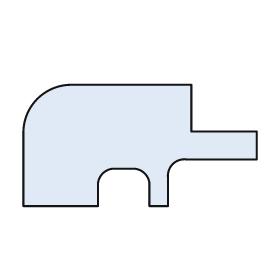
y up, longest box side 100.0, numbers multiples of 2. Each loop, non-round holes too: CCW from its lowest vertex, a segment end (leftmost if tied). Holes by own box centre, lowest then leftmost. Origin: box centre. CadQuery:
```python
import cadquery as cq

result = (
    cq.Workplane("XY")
    .moveTo(-50.0, -26.0)
    .lineTo(-18.0, -26.0)
    .lineTo(-18.0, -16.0)
    .threePointArc((-16.0, -12.0), (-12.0, -10.0))
    .lineTo(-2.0, -10.0)
    .threePointArc((2.0, -12.0), (4.0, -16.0))
    .lineTo(4.0, -26.0)
    .lineTo(12.0, -26.0)
    .lineTo(12.0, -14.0)
    .threePointArc((14.0, -8.0), (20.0, -6.0))
    .lineTo(50.0, -6.0)
    .lineTo(50.0, 6.0)
    .lineTo(22.0, 6.0)
    .lineTo(22.0, 26.0)
    .lineTo(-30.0, 26.0)
    .threePointArc((-44.0, 20.0), (-50.0, 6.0))
    .close()
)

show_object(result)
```